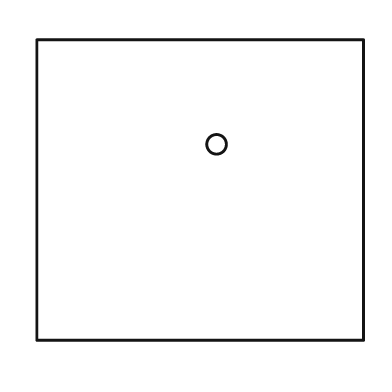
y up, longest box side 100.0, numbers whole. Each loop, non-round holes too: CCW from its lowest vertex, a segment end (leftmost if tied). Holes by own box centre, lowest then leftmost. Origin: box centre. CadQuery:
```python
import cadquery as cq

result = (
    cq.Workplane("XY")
    .moveTo(-50.0, -46.0)
    .lineTo(50.0, -46.0)
    .lineTo(50.0, 46.0)
    .lineTo(-50.0, 46.0)
    .close()
    .moveTo(5.0, 14.0)
    .circle(3.0)
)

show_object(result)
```